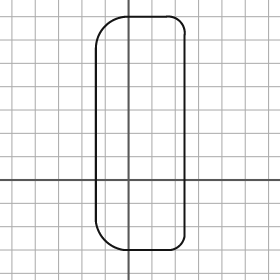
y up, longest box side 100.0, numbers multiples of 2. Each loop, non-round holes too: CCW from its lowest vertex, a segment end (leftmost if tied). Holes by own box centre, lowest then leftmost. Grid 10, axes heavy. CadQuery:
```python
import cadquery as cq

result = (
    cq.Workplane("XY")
    .moveTo(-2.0, -30.0)
    .lineTo(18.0, -30.0)
    .threePointArc((22.0, -28.0), (24.0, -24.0))
    .lineTo(24.0, 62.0)
    .threePointArc((22.0, 68.0), (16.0, 70.0))
    .lineTo(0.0, 70.0)
    .threePointArc((-10.0, 66.0), (-14.0, 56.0))
    .lineTo(-14.0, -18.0)
    .threePointArc((-10.0, -26.0), (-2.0, -30.0))
    .close()
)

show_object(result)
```